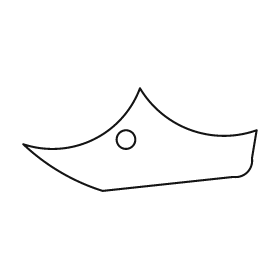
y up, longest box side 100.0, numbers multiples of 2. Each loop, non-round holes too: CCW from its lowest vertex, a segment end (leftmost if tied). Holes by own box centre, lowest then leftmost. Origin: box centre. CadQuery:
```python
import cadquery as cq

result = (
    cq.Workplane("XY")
    .moveTo(-16.0, -22.0)
    .lineTo(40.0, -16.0)
    .threePointArc((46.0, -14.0), (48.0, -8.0))
    .lineTo(50.0, 4.0)
    .threePointArc((22.0, 4.0), (0.0, 22.0))
    .threePointArc((-20.0, 0.0), (-50.0, -2.0))
    .threePointArc((-34.0, -14.0), (-16.0, -22.0))
    .close()
    .moveTo(-6.0, 0.0)
    .circle(4.0)
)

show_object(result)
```